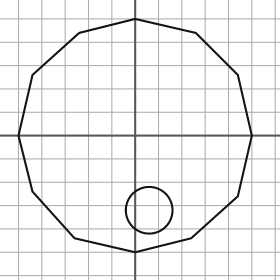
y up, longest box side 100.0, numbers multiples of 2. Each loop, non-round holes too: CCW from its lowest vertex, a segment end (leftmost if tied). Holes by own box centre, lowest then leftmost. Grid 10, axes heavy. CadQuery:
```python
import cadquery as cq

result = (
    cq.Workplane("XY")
    .moveTo(0.0, -50.0)
    .lineTo(24.0, -44.0)
    .lineTo(44.0, -26.0)
    .lineTo(50.0, 0.0)
    .lineTo(44.0, 26.0)
    .lineTo(26.0, 44.0)
    .lineTo(0.0, 50.0)
    .lineTo(-24.0, 44.0)
    .lineTo(-44.0, 26.0)
    .lineTo(-50.0, 0.0)
    .lineTo(-44.0, -24.0)
    .lineTo(-26.0, -44.0)
    .close()
    .moveTo(6.0, -32.0)
    .circle(10.0)
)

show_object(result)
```